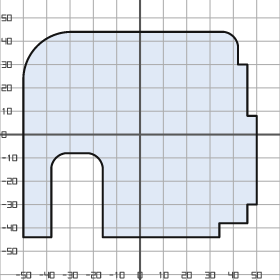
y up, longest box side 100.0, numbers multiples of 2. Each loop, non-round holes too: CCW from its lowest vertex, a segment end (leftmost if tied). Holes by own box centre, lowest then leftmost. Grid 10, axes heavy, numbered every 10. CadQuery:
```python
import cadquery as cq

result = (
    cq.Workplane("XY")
    .moveTo(-50.0, -44.0)
    .lineTo(-38.0, -44.0)
    .lineTo(-38.0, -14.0)
    .threePointArc((-36.0, -10.0), (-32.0, -8.0))
    .lineTo(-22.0, -8.0)
    .threePointArc((-18.0, -10.0), (-16.0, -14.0))
    .lineTo(-16.0, -44.0)
    .lineTo(34.0, -44.0)
    .lineTo(34.0, -38.0)
    .lineTo(46.0, -38.0)
    .lineTo(46.0, -30.0)
    .lineTo(50.0, -30.0)
    .lineTo(50.0, 8.0)
    .lineTo(46.0, 8.0)
    .lineTo(46.0, 30.0)
    .lineTo(42.0, 30.0)
    .lineTo(42.0, 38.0)
    .threePointArc((40.0, 42.0), (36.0, 44.0))
    .lineTo(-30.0, 44.0)
    .threePointArc((-44.0, 38.0), (-50.0, 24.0))
    .close()
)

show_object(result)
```